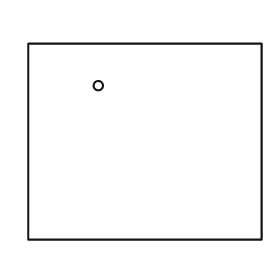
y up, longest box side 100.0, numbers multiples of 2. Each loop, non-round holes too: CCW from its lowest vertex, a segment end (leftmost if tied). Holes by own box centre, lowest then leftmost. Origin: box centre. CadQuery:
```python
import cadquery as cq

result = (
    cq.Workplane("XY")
    .moveTo(-50.0, -42.0)
    .lineTo(50.0, -42.0)
    .lineTo(50.0, 42.0)
    .lineTo(-50.0, 42.0)
    .close()
    .moveTo(-20.0, 24.0)
    .circle(2.0)
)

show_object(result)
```